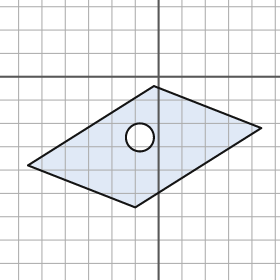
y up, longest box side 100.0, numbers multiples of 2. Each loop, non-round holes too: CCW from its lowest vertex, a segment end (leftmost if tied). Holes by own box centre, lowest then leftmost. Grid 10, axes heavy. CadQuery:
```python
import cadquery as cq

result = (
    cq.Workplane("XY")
    .moveTo(-10.0, -56.0)
    .lineTo(44.0, -22.0)
    .lineTo(-2.0, -4.0)
    .lineTo(-56.0, -38.0)
    .close()
    .moveTo(-8.0, -26.0)
    .circle(6.0)
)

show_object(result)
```